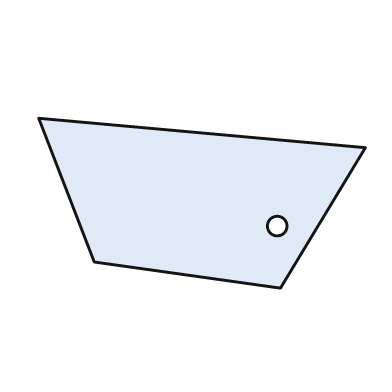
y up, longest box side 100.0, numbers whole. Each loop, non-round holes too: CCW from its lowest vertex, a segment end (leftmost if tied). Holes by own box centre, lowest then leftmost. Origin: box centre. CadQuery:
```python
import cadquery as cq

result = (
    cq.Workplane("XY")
    .moveTo(24.0, -26.0)
    .lineTo(50.0, 17.0)
    .lineTo(-50.0, 26.0)
    .lineTo(-33.0, -18.0)
    .close()
    .moveTo(23.0, -7.0)
    .circle(3.0)
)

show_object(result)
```